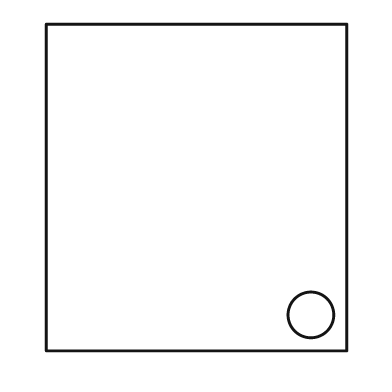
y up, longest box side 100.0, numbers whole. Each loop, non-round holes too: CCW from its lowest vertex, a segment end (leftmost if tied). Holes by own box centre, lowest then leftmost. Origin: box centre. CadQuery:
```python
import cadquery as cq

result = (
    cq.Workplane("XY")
    .moveTo(-46.0, -50.0)
    .lineTo(46.0, -50.0)
    .lineTo(46.0, 50.0)
    .lineTo(-46.0, 50.0)
    .close()
    .moveTo(35.0, -39.0)
    .circle(7.0)
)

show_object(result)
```